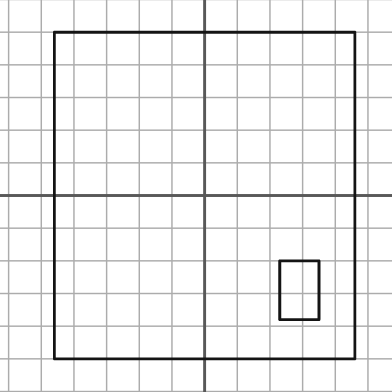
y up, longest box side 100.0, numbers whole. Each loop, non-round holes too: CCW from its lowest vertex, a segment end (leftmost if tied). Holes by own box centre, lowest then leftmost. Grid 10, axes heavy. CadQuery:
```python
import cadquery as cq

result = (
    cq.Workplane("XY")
    .moveTo(-46.0, -50.0)
    .lineTo(46.0, -50.0)
    .lineTo(46.0, 50.0)
    .lineTo(-46.0, 50.0)
    .close()
    .moveTo(23.0, -38.0)
    .lineTo(35.0, -38.0)
    .lineTo(35.0, -20.0)
    .lineTo(23.0, -20.0)
    .close()
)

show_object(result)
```